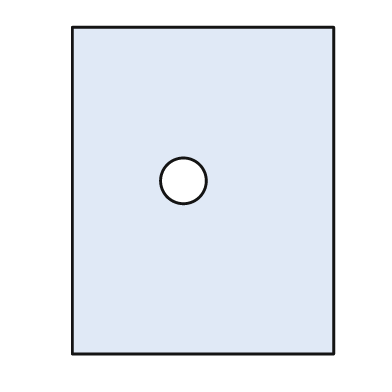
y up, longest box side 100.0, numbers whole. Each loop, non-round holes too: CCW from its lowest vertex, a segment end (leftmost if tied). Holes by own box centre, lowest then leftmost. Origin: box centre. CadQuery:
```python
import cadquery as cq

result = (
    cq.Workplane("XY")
    .moveTo(-40.0, -50.0)
    .lineTo(40.0, -50.0)
    .lineTo(40.0, 50.0)
    .lineTo(-40.0, 50.0)
    .close()
    .moveTo(-6.0, 3.0)
    .circle(7.0)
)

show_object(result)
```